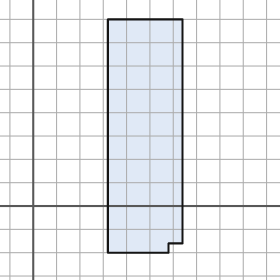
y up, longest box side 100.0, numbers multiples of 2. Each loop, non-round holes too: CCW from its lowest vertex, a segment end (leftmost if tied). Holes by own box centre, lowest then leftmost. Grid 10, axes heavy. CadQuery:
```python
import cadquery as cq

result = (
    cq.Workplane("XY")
    .moveTo(32.0, -20.0)
    .lineTo(58.0, -20.0)
    .lineTo(58.0, -16.0)
    .lineTo(64.0, -16.0)
    .lineTo(64.0, 80.0)
    .lineTo(32.0, 80.0)
    .close()
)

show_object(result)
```